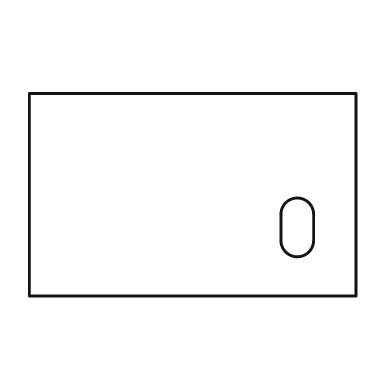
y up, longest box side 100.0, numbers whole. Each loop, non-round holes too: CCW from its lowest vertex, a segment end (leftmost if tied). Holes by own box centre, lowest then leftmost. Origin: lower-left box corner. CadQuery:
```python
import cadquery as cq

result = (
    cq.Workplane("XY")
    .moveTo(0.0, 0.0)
    .lineTo(100.0, 0.0)
    .lineTo(100.0, 62.0)
    .lineTo(0.0, 62.0)
    .close()
    .moveTo(77.0, 17.0)
    .threePointArc((82.0, 12.0), (87.0, 17.0))
    .lineTo(87.0, 25.0)
    .threePointArc((82.0, 30.0), (77.0, 25.0))
    .close()
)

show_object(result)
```